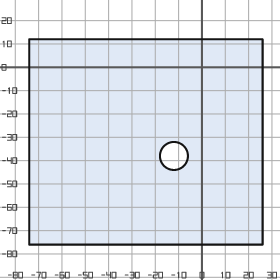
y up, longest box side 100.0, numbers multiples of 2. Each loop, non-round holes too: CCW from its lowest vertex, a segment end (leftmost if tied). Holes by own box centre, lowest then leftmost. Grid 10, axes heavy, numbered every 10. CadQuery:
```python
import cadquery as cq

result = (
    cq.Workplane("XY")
    .moveTo(-74.0, -76.0)
    .lineTo(26.0, -76.0)
    .lineTo(26.0, 12.0)
    .lineTo(-74.0, 12.0)
    .close()
    .moveTo(-12.0, -38.0)
    .circle(6.0)
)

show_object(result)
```